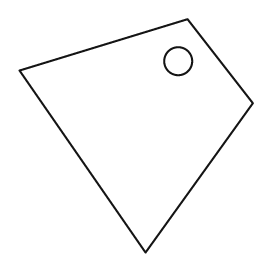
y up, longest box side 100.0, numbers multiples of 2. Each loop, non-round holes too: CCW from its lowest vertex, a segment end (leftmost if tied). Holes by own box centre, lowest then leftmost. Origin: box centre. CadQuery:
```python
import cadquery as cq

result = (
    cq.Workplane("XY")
    .moveTo(4.0, -50.0)
    .lineTo(50.0, 14.0)
    .lineTo(22.0, 50.0)
    .lineTo(-50.0, 28.0)
    .close()
    .moveTo(18.0, 32.0)
    .circle(6.0)
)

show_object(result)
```